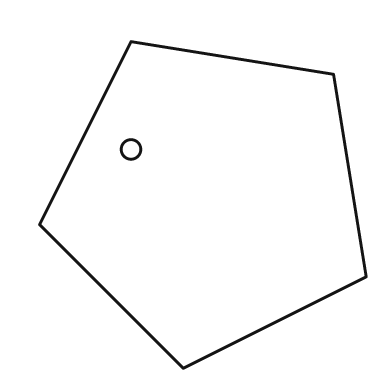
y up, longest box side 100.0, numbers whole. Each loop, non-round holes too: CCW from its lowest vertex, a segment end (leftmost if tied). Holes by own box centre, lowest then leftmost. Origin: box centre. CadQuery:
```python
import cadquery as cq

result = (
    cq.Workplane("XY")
    .moveTo(-6.0, -50.0)
    .lineTo(50.0, -22.0)
    .lineTo(40.0, 40.0)
    .lineTo(-22.0, 50.0)
    .lineTo(-50.0, -6.0)
    .close()
    .moveTo(-22.0, 17.0)
    .circle(3.0)
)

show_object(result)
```